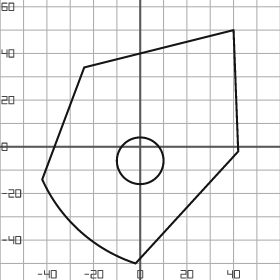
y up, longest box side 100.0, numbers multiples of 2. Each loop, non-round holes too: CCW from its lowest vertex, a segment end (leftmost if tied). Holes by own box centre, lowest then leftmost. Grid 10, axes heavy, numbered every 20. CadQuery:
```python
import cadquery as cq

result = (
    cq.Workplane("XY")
    .moveTo(-2.0, -50.0)
    .lineTo(42.0, -2.0)
    .lineTo(40.0, 50.0)
    .lineTo(-24.0, 34.0)
    .lineTo(-42.0, -14.0)
    .threePointArc((-26.0, -36.0), (-2.0, -50.0))
    .close()
    .moveTo(0.0, -6.0)
    .circle(10.0)
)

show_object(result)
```